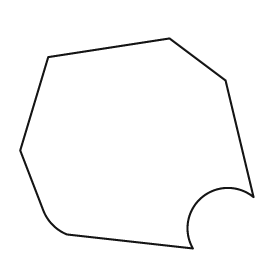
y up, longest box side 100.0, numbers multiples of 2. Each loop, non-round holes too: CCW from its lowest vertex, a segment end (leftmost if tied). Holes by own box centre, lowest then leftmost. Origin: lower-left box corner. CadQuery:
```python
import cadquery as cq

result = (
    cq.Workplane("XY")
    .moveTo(74.0, 0.0)
    .threePointArc((78.0, 22.0), (100.0, 22.0))
    .lineTo(88.0, 72.0)
    .lineTo(64.0, 90.0)
    .lineTo(12.0, 82.0)
    .lineTo(0.0, 42.0)
    .lineTo(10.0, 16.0)
    .threePointArc((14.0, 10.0), (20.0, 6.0))
    .close()
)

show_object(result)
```